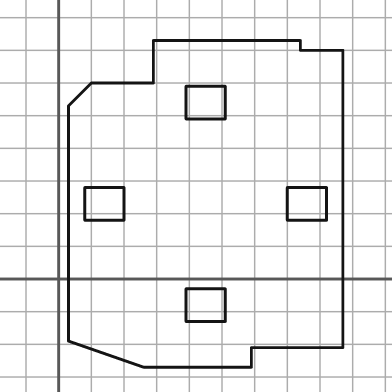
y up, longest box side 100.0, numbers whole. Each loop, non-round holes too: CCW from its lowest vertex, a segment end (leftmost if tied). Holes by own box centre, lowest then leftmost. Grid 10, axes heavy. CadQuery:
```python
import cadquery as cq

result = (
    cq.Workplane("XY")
    .moveTo(26.0, -27.0)
    .lineTo(59.0, -27.0)
    .lineTo(59.0, -21.0)
    .lineTo(87.0, -21.0)
    .lineTo(87.0, 70.0)
    .lineTo(74.0, 70.0)
    .lineTo(74.0, 73.0)
    .lineTo(29.0, 73.0)
    .lineTo(29.0, 60.0)
    .lineTo(10.0, 60.0)
    .lineTo(3.0, 53.0)
    .lineTo(3.0, -19.0)
    .close()
    .moveTo(39.0, -13.0)
    .lineTo(51.0, -13.0)
    .lineTo(51.0, -3.0)
    .lineTo(39.0, -3.0)
    .close()
    .moveTo(8.0, 18.0)
    .lineTo(20.0, 18.0)
    .lineTo(20.0, 28.0)
    .lineTo(8.0, 28.0)
    .close()
    .moveTo(70.0, 18.0)
    .lineTo(82.0, 18.0)
    .lineTo(82.0, 28.0)
    .lineTo(70.0, 28.0)
    .close()
    .moveTo(39.0, 49.0)
    .lineTo(51.0, 49.0)
    .lineTo(51.0, 59.0)
    .lineTo(39.0, 59.0)
    .close()
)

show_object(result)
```